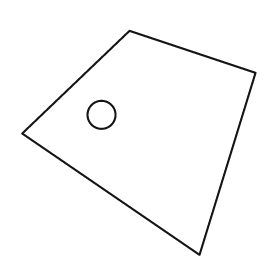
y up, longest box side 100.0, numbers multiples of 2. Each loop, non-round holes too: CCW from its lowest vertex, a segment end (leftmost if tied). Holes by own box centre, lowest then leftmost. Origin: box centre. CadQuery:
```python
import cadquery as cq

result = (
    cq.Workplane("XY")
    .moveTo(26.0, -48.0)
    .lineTo(50.0, 30.0)
    .lineTo(-4.0, 48.0)
    .lineTo(-50.0, 4.0)
    .close()
    .moveTo(-16.0, 12.0)
    .circle(6.0)
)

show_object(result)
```